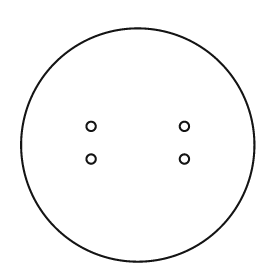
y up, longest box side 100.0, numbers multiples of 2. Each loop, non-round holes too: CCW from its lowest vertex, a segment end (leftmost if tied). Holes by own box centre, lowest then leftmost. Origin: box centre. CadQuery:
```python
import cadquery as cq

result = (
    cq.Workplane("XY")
    .moveTo(0.0, 0.0)
    .circle(50.0)
    .moveTo(-20.0, -6.0)
    .circle(2.0)
    .moveTo(20.0, -6.0)
    .circle(2.0)
    .moveTo(-20.0, 8.0)
    .circle(2.0)
    .moveTo(20.0, 8.0)
    .circle(2.0)
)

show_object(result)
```